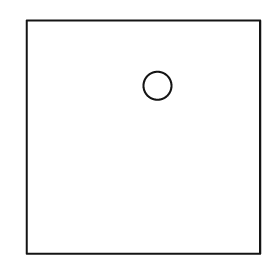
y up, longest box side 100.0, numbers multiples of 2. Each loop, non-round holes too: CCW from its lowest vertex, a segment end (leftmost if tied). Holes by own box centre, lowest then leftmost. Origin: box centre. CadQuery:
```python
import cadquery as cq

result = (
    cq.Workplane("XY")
    .moveTo(-50.0, -50.0)
    .lineTo(50.0, -50.0)
    .lineTo(50.0, 50.0)
    .lineTo(-50.0, 50.0)
    .close()
    .moveTo(6.0, 22.0)
    .circle(6.0)
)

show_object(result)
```